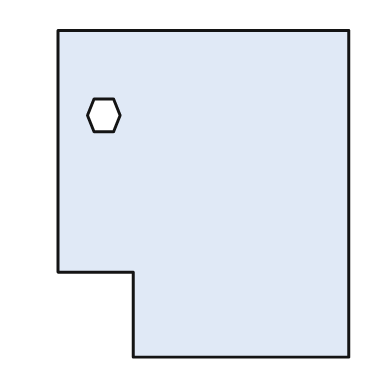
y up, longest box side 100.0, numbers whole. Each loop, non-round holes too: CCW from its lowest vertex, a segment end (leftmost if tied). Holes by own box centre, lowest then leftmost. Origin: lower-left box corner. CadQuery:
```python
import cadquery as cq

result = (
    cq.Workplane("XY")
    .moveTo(23.0, 0.0)
    .lineTo(89.0, 0.0)
    .lineTo(89.0, 100.0)
    .lineTo(0.0, 100.0)
    .lineTo(0.0, 26.0)
    .lineTo(23.0, 26.0)
    .close()
    .moveTo(11.0, 69.0)
    .lineTo(17.0, 69.0)
    .lineTo(19.0, 74.0)
    .lineTo(17.0, 79.0)
    .lineTo(11.0, 79.0)
    .lineTo(9.0, 74.0)
    .close()
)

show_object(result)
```